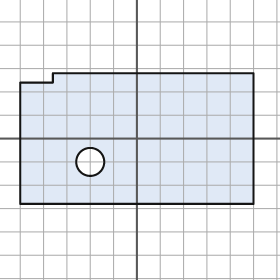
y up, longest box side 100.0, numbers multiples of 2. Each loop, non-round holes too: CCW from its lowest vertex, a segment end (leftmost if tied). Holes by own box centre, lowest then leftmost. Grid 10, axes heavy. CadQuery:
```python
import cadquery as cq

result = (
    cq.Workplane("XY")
    .moveTo(-50.0, -28.0)
    .lineTo(50.0, -28.0)
    .lineTo(50.0, 28.0)
    .lineTo(-36.0, 28.0)
    .lineTo(-36.0, 24.0)
    .lineTo(-50.0, 24.0)
    .close()
    .moveTo(-20.0, -10.0)
    .circle(6.0)
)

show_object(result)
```